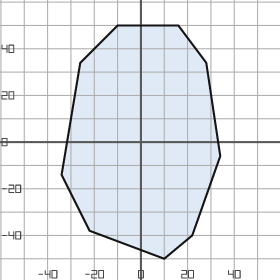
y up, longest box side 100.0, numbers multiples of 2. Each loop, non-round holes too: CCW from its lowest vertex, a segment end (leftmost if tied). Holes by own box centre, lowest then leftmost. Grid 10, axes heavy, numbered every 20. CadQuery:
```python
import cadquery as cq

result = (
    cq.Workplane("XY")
    .moveTo(10.0, -50.0)
    .lineTo(22.0, -40.0)
    .lineTo(34.0, -6.0)
    .lineTo(28.0, 34.0)
    .lineTo(16.0, 50.0)
    .lineTo(-10.0, 50.0)
    .lineTo(-26.0, 34.0)
    .lineTo(-34.0, -14.0)
    .lineTo(-22.0, -38.0)
    .close()
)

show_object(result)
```